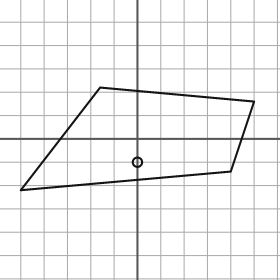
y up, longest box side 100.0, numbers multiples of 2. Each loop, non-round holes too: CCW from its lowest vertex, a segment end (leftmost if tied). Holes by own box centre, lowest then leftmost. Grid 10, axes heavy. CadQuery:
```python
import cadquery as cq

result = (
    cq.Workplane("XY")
    .moveTo(-50.0, -22.0)
    .lineTo(40.0, -14.0)
    .lineTo(50.0, 16.0)
    .lineTo(-16.0, 22.0)
    .close()
    .moveTo(0.0, -10.0)
    .circle(2.0)
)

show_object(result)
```